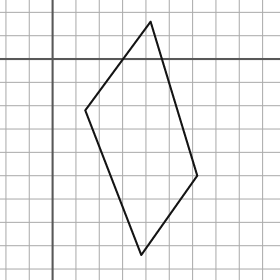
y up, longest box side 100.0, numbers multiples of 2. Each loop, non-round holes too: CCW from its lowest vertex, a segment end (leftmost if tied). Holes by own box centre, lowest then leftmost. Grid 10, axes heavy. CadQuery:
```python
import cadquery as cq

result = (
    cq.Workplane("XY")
    .moveTo(38.0, -84.0)
    .lineTo(62.0, -50.0)
    .lineTo(42.0, 16.0)
    .lineTo(14.0, -22.0)
    .close()
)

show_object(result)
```